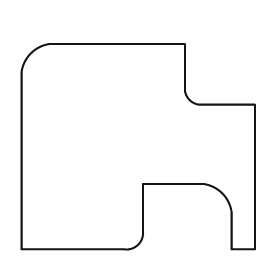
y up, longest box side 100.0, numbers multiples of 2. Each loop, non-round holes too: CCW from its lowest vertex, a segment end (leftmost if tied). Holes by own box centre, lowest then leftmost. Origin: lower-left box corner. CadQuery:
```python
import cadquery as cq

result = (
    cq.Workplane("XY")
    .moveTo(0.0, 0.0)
    .lineTo(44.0, 0.0)
    .threePointArc((50.0, 2.0), (52.0, 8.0))
    .lineTo(52.0, 28.0)
    .lineTo(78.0, 28.0)
    .threePointArc((86.0, 24.0), (90.0, 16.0))
    .lineTo(90.0, 0.0)
    .lineTo(100.0, 0.0)
    .lineTo(100.0, 62.0)
    .lineTo(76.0, 62.0)
    .threePointArc((72.0, 64.0), (70.0, 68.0))
    .lineTo(70.0, 88.0)
    .lineTo(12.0, 88.0)
    .threePointArc((4.0, 84.0), (0.0, 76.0))
    .close()
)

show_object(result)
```